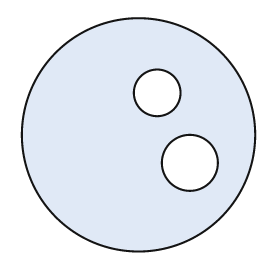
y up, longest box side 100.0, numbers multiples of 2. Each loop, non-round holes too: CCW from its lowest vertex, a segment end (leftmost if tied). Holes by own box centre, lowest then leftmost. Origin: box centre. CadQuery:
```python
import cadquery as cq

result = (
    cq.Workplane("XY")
    .moveTo(0.0, 0.0)
    .circle(50.0)
    .moveTo(22.0, -12.0)
    .circle(12.0)
    .moveTo(8.0, 18.0)
    .circle(10.0)
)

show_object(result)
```